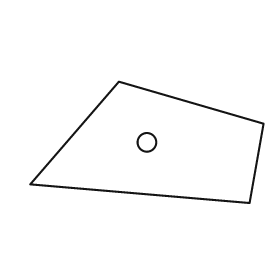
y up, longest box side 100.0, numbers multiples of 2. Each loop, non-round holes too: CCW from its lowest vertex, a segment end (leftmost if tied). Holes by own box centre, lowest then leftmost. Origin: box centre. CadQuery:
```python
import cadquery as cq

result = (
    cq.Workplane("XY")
    .moveTo(44.0, -26.0)
    .lineTo(50.0, 8.0)
    .lineTo(-12.0, 26.0)
    .lineTo(-50.0, -18.0)
    .close()
    .moveTo(0.0, 0.0)
    .circle(4.0)
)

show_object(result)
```